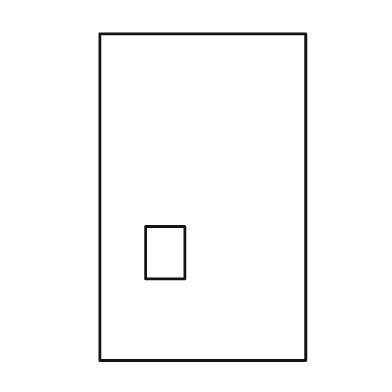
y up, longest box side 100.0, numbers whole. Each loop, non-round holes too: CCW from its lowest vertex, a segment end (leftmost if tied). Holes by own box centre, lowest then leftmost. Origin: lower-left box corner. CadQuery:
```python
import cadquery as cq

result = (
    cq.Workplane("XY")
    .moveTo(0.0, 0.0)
    .lineTo(63.0, 0.0)
    .lineTo(63.0, 100.0)
    .lineTo(0.0, 100.0)
    .close()
    .moveTo(14.0, 25.0)
    .lineTo(26.0, 25.0)
    .lineTo(26.0, 41.0)
    .lineTo(14.0, 41.0)
    .close()
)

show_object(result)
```